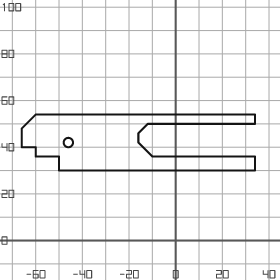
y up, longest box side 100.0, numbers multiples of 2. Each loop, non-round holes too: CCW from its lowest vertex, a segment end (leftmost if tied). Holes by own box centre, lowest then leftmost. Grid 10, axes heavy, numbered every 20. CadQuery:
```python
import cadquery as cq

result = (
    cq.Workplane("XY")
    .moveTo(-50.0, 30.0)
    .lineTo(34.0, 30.0)
    .lineTo(34.0, 36.0)
    .lineTo(-10.0, 36.0)
    .lineTo(-16.0, 42.0)
    .lineTo(-16.0, 46.0)
    .lineTo(-12.0, 50.0)
    .lineTo(34.0, 50.0)
    .lineTo(34.0, 54.0)
    .lineTo(-60.0, 54.0)
    .lineTo(-66.0, 48.0)
    .lineTo(-66.0, 40.0)
    .lineTo(-60.0, 40.0)
    .lineTo(-60.0, 36.0)
    .lineTo(-50.0, 36.0)
    .close()
    .moveTo(-46.0, 42.0)
    .circle(2.0)
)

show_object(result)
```